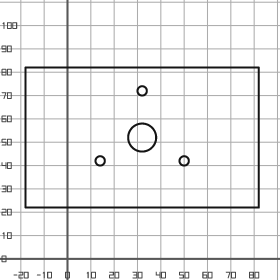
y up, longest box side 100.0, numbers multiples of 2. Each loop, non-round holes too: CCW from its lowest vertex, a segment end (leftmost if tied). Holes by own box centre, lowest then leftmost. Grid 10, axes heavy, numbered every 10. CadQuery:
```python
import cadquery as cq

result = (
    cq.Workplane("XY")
    .moveTo(-18.0, 22.0)
    .lineTo(82.0, 22.0)
    .lineTo(82.0, 82.0)
    .lineTo(-18.0, 82.0)
    .close()
    .moveTo(14.0, 42.0)
    .circle(2.0)
    .moveTo(50.0, 42.0)
    .circle(2.0)
    .moveTo(32.0, 52.0)
    .circle(6.0)
    .moveTo(32.0, 72.0)
    .circle(2.0)
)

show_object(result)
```